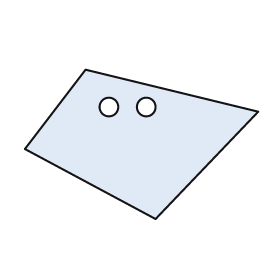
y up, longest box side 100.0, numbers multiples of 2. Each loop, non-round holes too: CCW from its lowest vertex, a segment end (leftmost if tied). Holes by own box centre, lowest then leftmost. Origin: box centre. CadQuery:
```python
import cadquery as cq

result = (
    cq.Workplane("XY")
    .moveTo(6.0, -32.0)
    .lineTo(50.0, 14.0)
    .lineTo(-24.0, 32.0)
    .lineTo(-50.0, -2.0)
    .close()
    .moveTo(-14.0, 16.0)
    .circle(4.0)
    .moveTo(2.0, 16.0)
    .circle(4.0)
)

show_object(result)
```